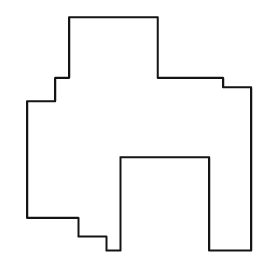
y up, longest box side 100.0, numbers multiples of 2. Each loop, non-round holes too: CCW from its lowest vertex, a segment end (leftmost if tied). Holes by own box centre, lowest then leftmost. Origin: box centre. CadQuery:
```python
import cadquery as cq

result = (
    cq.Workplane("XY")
    .moveTo(-14.0, -50.0)
    .lineTo(-8.0, -50.0)
    .lineTo(-8.0, -10.0)
    .lineTo(30.0, -10.0)
    .lineTo(30.0, -50.0)
    .lineTo(48.0, -50.0)
    .lineTo(48.0, 20.0)
    .lineTo(36.0, 20.0)
    .lineTo(36.0, 24.0)
    .lineTo(8.0, 24.0)
    .lineTo(8.0, 50.0)
    .lineTo(-30.0, 50.0)
    .lineTo(-30.0, 24.0)
    .lineTo(-36.0, 24.0)
    .lineTo(-36.0, 14.0)
    .lineTo(-48.0, 14.0)
    .lineTo(-48.0, -36.0)
    .lineTo(-26.0, -36.0)
    .lineTo(-26.0, -44.0)
    .lineTo(-14.0, -44.0)
    .close()
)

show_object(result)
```